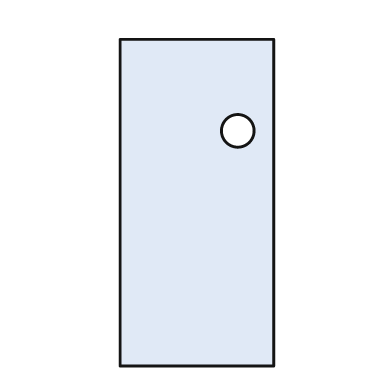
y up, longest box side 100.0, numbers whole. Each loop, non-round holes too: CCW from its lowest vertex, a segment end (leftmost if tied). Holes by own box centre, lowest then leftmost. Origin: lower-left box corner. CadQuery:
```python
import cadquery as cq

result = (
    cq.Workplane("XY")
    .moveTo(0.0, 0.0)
    .lineTo(47.0, 0.0)
    .lineTo(47.0, 100.0)
    .lineTo(0.0, 100.0)
    .close()
    .moveTo(36.0, 72.0)
    .circle(5.0)
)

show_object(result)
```